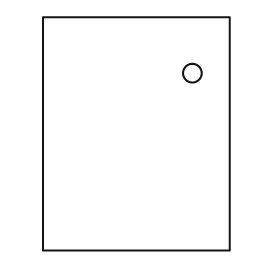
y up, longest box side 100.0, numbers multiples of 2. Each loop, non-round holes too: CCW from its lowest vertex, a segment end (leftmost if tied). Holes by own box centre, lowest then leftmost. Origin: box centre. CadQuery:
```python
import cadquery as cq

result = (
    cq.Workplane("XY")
    .moveTo(-40.0, -50.0)
    .lineTo(40.0, -50.0)
    .lineTo(40.0, 50.0)
    .lineTo(-40.0, 50.0)
    .close()
    .moveTo(24.0, 26.0)
    .circle(4.0)
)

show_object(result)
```